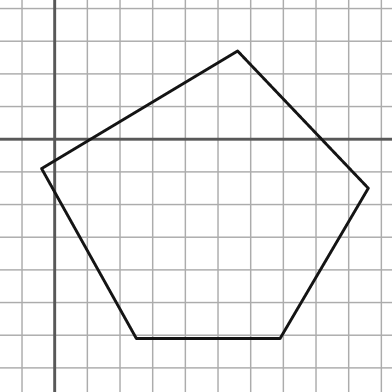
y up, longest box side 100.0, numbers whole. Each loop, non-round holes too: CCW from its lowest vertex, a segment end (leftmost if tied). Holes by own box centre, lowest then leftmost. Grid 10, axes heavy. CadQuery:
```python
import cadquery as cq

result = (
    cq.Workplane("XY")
    .moveTo(25.0, -61.0)
    .lineTo(69.0, -61.0)
    .lineTo(96.0, -15.0)
    .lineTo(56.0, 27.0)
    .lineTo(-4.0, -9.0)
    .close()
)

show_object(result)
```